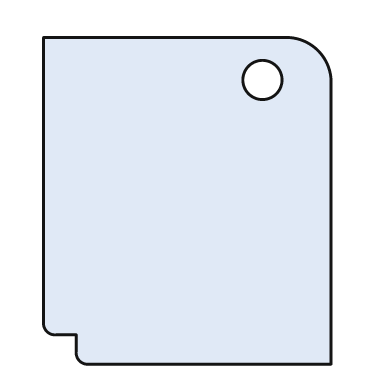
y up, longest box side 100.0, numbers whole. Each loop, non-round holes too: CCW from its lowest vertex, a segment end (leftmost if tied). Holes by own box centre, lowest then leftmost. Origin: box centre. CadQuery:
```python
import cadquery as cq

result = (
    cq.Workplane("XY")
    .moveTo(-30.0, -50.0)
    .lineTo(44.0, -50.0)
    .lineTo(44.0, 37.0)
    .threePointArc((40.0, 46.0), (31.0, 50.0))
    .lineTo(-44.0, 50.0)
    .lineTo(-44.0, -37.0)
    .threePointArc((-43.0, -40.0), (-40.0, -41.0))
    .lineTo(-34.0, -41.0)
    .lineTo(-34.0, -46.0)
    .threePointArc((-33.0, -49.0), (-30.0, -50.0))
    .close()
    .moveTo(23.0, 37.0)
    .circle(6.0)
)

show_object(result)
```